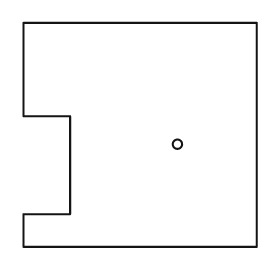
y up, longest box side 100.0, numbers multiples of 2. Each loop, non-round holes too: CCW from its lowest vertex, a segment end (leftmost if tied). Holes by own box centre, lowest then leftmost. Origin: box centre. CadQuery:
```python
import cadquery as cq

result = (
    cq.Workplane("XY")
    .moveTo(-50.0, -48.0)
    .lineTo(50.0, -48.0)
    .lineTo(50.0, 48.0)
    .lineTo(-50.0, 48.0)
    .lineTo(-50.0, 8.0)
    .lineTo(-30.0, 8.0)
    .lineTo(-30.0, -34.0)
    .lineTo(-50.0, -34.0)
    .close()
    .moveTo(16.0, -4.0)
    .circle(2.0)
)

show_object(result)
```